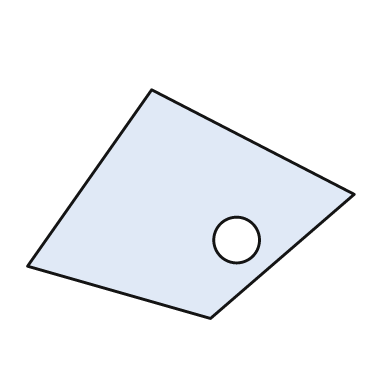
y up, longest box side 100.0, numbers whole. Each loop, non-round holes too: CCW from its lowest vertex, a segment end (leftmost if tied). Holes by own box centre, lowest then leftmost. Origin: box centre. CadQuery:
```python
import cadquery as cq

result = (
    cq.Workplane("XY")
    .moveTo(6.0, -35.0)
    .lineTo(50.0, 3.0)
    .lineTo(-12.0, 35.0)
    .lineTo(-50.0, -19.0)
    .close()
    .moveTo(14.0, -11.0)
    .circle(7.0)
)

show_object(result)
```